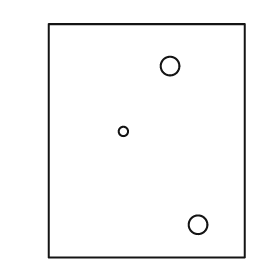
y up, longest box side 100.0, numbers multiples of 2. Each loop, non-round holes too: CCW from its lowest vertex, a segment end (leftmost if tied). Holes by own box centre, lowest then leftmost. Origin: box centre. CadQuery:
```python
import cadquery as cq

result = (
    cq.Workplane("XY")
    .moveTo(-42.0, -50.0)
    .lineTo(42.0, -50.0)
    .lineTo(42.0, 50.0)
    .lineTo(-42.0, 50.0)
    .close()
    .moveTo(22.0, -36.0)
    .circle(4.0)
    .moveTo(-10.0, 4.0)
    .circle(2.0)
    .moveTo(10.0, 32.0)
    .circle(4.0)
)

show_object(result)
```